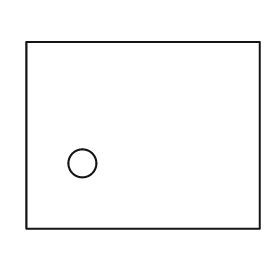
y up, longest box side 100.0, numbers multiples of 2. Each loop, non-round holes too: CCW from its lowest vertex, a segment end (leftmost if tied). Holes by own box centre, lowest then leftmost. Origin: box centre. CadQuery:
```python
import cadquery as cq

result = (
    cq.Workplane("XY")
    .moveTo(-50.0, -40.0)
    .lineTo(50.0, -40.0)
    .lineTo(50.0, 40.0)
    .lineTo(-50.0, 40.0)
    .close()
    .moveTo(-26.0, -12.0)
    .circle(6.0)
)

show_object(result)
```